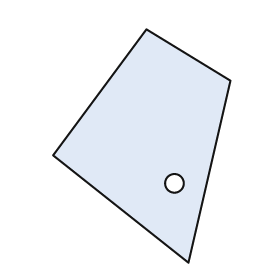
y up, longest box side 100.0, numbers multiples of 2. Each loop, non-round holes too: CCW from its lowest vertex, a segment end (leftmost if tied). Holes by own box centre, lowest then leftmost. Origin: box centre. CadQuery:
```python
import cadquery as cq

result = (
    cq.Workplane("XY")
    .moveTo(20.0, -50.0)
    .lineTo(38.0, 28.0)
    .lineTo(2.0, 50.0)
    .lineTo(-38.0, -4.0)
    .close()
    .moveTo(14.0, -16.0)
    .circle(4.0)
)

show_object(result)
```